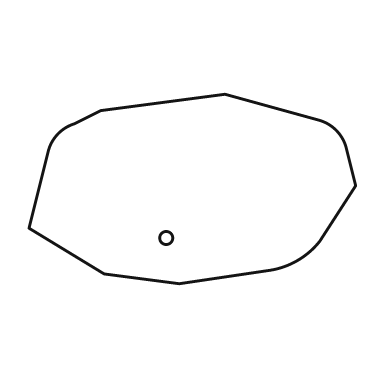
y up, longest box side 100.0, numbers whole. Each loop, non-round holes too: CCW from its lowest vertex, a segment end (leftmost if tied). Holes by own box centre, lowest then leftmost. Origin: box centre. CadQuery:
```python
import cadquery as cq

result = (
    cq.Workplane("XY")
    .moveTo(-4.0, -29.0)
    .lineTo(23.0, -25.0)
    .threePointArc((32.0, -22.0), (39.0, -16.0))
    .lineTo(50.0, 1.0)
    .lineTo(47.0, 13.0)
    .threePointArc((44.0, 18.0), (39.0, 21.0))
    .lineTo(10.0, 29.0)
    .lineTo(-28.0, 24.0)
    .lineTo(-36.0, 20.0)
    .threePointArc((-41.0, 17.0), (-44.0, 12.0))
    .lineTo(-50.0, -12.0)
    .lineTo(-27.0, -26.0)
    .close()
    .moveTo(-8.0, -15.0)
    .circle(2.0)
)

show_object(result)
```